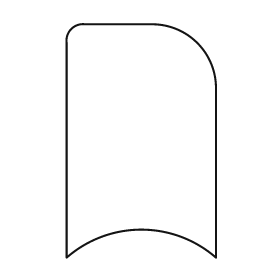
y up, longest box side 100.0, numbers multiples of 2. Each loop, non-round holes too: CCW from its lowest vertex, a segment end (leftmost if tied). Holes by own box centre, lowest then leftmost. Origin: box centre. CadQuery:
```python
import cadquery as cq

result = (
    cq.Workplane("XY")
    .moveTo(-32.0, -50.0)
    .threePointArc((0.0, -38.0), (32.0, -50.0))
    .lineTo(32.0, 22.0)
    .threePointArc((24.0, 42.0), (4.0, 50.0))
    .lineTo(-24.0, 50.0)
    .threePointArc((-30.0, 48.0), (-32.0, 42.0))
    .close()
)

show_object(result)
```